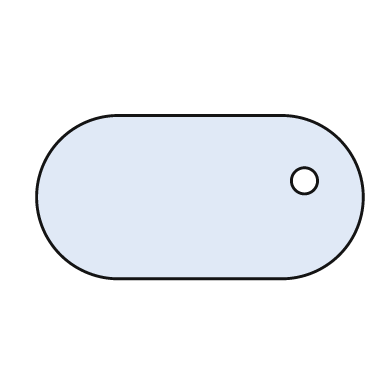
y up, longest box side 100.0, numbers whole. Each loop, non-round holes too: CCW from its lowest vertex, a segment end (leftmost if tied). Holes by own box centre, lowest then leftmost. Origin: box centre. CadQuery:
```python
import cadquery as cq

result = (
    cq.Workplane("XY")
    .moveTo(-25.0, -25.0)
    .lineTo(25.0, -25.0)
    .threePointArc((50.0, 0.0), (25.0, 25.0))
    .lineTo(-25.0, 25.0)
    .threePointArc((-50.0, 0.0), (-25.0, -25.0))
    .close()
    .moveTo(32.0, 5.0)
    .circle(4.0)
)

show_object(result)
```